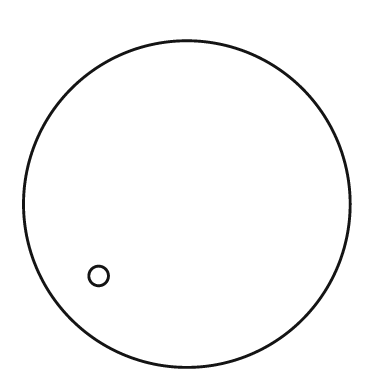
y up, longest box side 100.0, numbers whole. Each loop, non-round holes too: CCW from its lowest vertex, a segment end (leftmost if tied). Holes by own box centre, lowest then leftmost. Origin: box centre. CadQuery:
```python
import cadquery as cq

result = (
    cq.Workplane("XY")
    .moveTo(0.0, 0.0)
    .circle(50.0)
    .moveTo(-27.0, -22.0)
    .circle(3.0)
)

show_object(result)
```